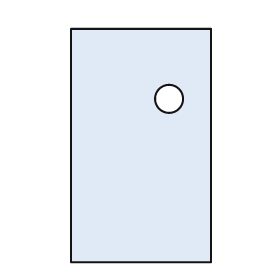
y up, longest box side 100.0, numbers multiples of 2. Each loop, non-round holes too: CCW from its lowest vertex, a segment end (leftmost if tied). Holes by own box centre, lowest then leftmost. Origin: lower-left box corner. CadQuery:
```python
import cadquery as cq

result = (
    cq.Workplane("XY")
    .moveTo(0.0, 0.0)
    .lineTo(60.0, 0.0)
    .lineTo(60.0, 100.0)
    .lineTo(0.0, 100.0)
    .close()
    .moveTo(42.0, 70.0)
    .circle(6.0)
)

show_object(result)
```